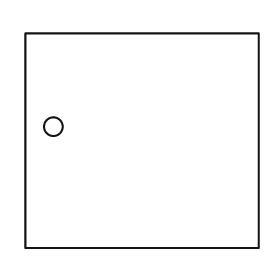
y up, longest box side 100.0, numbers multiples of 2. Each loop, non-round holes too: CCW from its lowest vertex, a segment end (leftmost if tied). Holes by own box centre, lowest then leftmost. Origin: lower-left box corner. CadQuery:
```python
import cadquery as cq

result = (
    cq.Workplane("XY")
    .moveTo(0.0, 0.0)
    .lineTo(100.0, 0.0)
    .lineTo(100.0, 92.0)
    .lineTo(0.0, 92.0)
    .close()
    .moveTo(12.0, 52.0)
    .circle(4.0)
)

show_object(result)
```